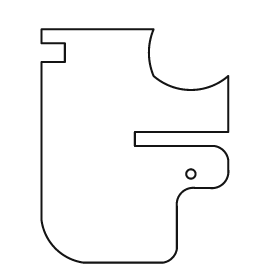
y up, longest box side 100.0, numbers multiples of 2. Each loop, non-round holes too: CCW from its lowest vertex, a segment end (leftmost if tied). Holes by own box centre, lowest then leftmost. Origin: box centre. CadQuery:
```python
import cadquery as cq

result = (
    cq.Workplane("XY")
    .moveTo(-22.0, -50.0)
    .lineTo(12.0, -50.0)
    .threePointArc((16.0, -48.0), (18.0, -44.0))
    .lineTo(18.0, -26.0)
    .threePointArc((20.0, -20.0), (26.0, -18.0))
    .lineTo(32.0, -18.0)
    .threePointArc((38.0, -16.0), (40.0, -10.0))
    .lineTo(40.0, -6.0)
    .threePointArc((38.0, -2.0), (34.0, 0.0))
    .lineTo(0.0, 0.0)
    .lineTo(0.0, 6.0)
    .lineTo(40.0, 6.0)
    .lineTo(40.0, 30.0)
    .threePointArc((24.0, 24.0), (8.0, 30.0))
    .threePointArc((6.0, 40.0), (8.0, 50.0))
    .lineTo(-40.0, 50.0)
    .lineTo(-40.0, 44.0)
    .lineTo(-30.0, 44.0)
    .lineTo(-30.0, 36.0)
    .lineTo(-40.0, 36.0)
    .lineTo(-40.0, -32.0)
    .threePointArc((-34.0, -44.0), (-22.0, -50.0))
    .close()
    .moveTo(24.0, -12.0)
    .circle(2.0)
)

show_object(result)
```